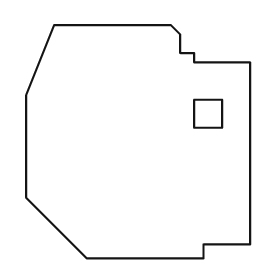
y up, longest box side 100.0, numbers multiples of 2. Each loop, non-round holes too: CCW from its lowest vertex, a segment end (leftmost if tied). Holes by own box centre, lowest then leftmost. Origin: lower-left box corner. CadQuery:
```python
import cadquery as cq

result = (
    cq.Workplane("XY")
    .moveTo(26.0, 0.0)
    .lineTo(76.0, 0.0)
    .lineTo(76.0, 6.0)
    .lineTo(96.0, 6.0)
    .lineTo(96.0, 84.0)
    .lineTo(72.0, 84.0)
    .lineTo(72.0, 88.0)
    .lineTo(66.0, 88.0)
    .lineTo(66.0, 96.0)
    .lineTo(62.0, 100.0)
    .lineTo(12.0, 100.0)
    .lineTo(0.0, 70.0)
    .lineTo(0.0, 26.0)
    .close()
    .moveTo(72.0, 56.0)
    .lineTo(84.0, 56.0)
    .lineTo(84.0, 68.0)
    .lineTo(72.0, 68.0)
    .close()
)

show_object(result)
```